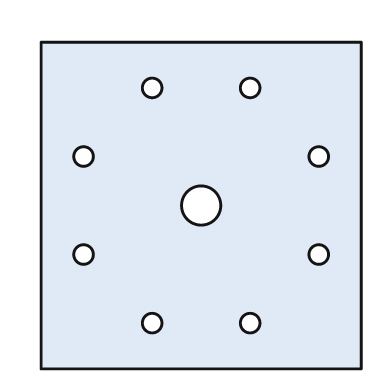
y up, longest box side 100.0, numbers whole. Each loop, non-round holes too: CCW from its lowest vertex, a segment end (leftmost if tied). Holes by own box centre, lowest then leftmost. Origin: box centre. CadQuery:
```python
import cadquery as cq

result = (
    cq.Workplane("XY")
    .moveTo(-49.0, -50.0)
    .lineTo(49.0, -50.0)
    .lineTo(49.0, 50.0)
    .lineTo(-49.0, 50.0)
    .close()
    .moveTo(-15.0, -36.0)
    .circle(3.0)
    .moveTo(15.0, -36.0)
    .circle(3.0)
    .moveTo(-36.0, -15.0)
    .circle(3.0)
    .moveTo(36.0, -15.0)
    .circle(3.0)
    .moveTo(0.0, 0.0)
    .circle(6.0)
    .moveTo(-36.0, 15.0)
    .circle(3.0)
    .moveTo(36.0, 15.0)
    .circle(3.0)
    .moveTo(-15.0, 36.0)
    .circle(3.0)
    .moveTo(15.0, 36.0)
    .circle(3.0)
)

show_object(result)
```